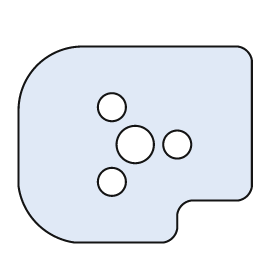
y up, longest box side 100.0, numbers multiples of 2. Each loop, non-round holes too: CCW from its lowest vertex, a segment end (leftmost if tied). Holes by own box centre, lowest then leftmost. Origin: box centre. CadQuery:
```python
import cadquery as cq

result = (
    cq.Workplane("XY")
    .moveTo(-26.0, -42.0)
    .lineTo(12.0, -42.0)
    .threePointArc((16.0, -40.0), (18.0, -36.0))
    .lineTo(18.0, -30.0)
    .threePointArc((20.0, -26.0), (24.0, -24.0))
    .lineTo(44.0, -24.0)
    .threePointArc((48.0, -22.0), (50.0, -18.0))
    .lineTo(50.0, 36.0)
    .threePointArc((48.0, 40.0), (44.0, 42.0))
    .lineTo(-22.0, 42.0)
    .threePointArc((-42.0, 34.0), (-50.0, 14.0))
    .lineTo(-50.0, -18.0)
    .threePointArc((-42.0, -34.0), (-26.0, -42.0))
    .close()
    .moveTo(-10.0, -16.0)
    .circle(6.0)
    .moveTo(0.0, 0.0)
    .circle(8.0)
    .moveTo(18.0, 0.0)
    .circle(6.0)
    .moveTo(-10.0, 16.0)
    .circle(6.0)
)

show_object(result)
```